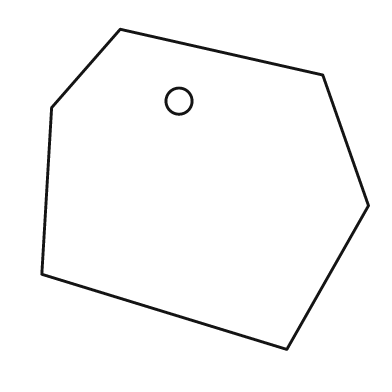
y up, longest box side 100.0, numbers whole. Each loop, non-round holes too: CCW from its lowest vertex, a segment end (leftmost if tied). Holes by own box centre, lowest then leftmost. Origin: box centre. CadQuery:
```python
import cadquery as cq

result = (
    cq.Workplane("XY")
    .moveTo(25.0, -49.0)
    .lineTo(50.0, -5.0)
    .lineTo(36.0, 35.0)
    .lineTo(-26.0, 49.0)
    .lineTo(-47.0, 25.0)
    .lineTo(-50.0, -26.0)
    .close()
    .moveTo(-8.0, 27.0)
    .circle(4.0)
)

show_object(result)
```